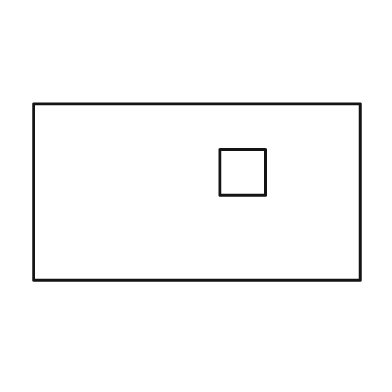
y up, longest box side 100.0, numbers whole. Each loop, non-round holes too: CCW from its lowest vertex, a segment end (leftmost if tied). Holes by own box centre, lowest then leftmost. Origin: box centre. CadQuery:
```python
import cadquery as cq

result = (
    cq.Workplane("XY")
    .moveTo(-50.0, -27.0)
    .lineTo(50.0, -27.0)
    .lineTo(50.0, 27.0)
    .lineTo(-50.0, 27.0)
    .close()
    .moveTo(7.0, -1.0)
    .lineTo(21.0, -1.0)
    .lineTo(21.0, 13.0)
    .lineTo(7.0, 13.0)
    .close()
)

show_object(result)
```